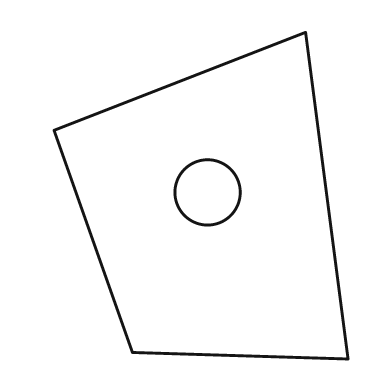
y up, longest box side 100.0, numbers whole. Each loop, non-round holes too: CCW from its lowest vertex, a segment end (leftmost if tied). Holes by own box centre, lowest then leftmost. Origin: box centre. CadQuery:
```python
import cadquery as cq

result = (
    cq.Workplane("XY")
    .moveTo(45.0, -50.0)
    .lineTo(32.0, 50.0)
    .lineTo(-45.0, 20.0)
    .lineTo(-21.0, -48.0)
    .close()
    .moveTo(2.0, 1.0)
    .circle(10.0)
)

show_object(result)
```